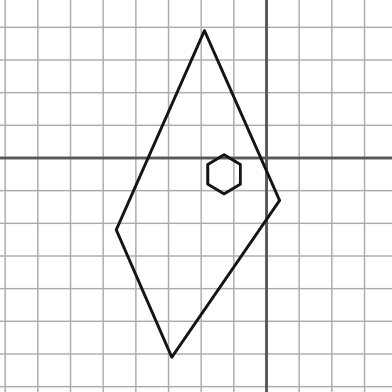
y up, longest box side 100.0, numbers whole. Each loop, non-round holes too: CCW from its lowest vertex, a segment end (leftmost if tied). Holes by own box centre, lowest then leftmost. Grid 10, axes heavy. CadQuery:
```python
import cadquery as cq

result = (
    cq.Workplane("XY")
    .moveTo(-29.0, -61.0)
    .lineTo(4.0, -13.0)
    .lineTo(-19.0, 39.0)
    .lineTo(-46.0, -22.0)
    .close()
    .moveTo(-13.0, -11.0)
    .lineTo(-8.0, -8.0)
    .lineTo(-8.0, -2.0)
    .lineTo(-13.0, 1.0)
    .lineTo(-18.0, -2.0)
    .lineTo(-18.0, -8.0)
    .close()
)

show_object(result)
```